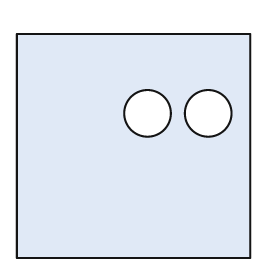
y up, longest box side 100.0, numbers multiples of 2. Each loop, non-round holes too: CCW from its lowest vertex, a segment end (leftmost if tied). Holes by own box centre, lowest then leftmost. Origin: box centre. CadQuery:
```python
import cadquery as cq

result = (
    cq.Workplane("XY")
    .moveTo(-50.0, -48.0)
    .lineTo(50.0, -48.0)
    .lineTo(50.0, 48.0)
    .lineTo(-50.0, 48.0)
    .close()
    .moveTo(6.0, 14.0)
    .circle(10.0)
    .moveTo(32.0, 14.0)
    .circle(10.0)
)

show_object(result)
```